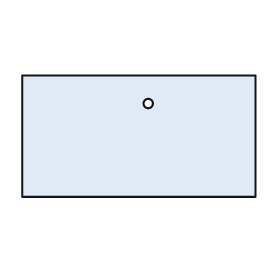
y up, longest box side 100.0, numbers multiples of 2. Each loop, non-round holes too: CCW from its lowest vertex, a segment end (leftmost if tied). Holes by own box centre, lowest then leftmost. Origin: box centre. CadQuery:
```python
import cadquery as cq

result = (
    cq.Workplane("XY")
    .moveTo(-50.0, -26.0)
    .lineTo(50.0, -26.0)
    .lineTo(50.0, 26.0)
    .lineTo(-50.0, 26.0)
    .close()
    .moveTo(4.0, 14.0)
    .circle(2.0)
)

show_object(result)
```